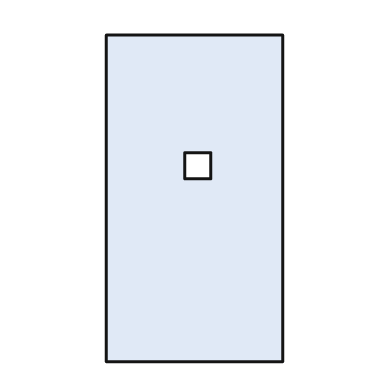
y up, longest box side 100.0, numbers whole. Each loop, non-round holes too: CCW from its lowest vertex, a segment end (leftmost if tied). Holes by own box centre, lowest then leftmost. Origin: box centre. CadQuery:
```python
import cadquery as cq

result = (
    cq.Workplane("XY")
    .moveTo(-27.0, -50.0)
    .lineTo(27.0, -50.0)
    .lineTo(27.0, 50.0)
    .lineTo(-27.0, 50.0)
    .close()
    .moveTo(-3.0, 6.0)
    .lineTo(5.0, 6.0)
    .lineTo(5.0, 14.0)
    .lineTo(-3.0, 14.0)
    .close()
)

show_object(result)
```